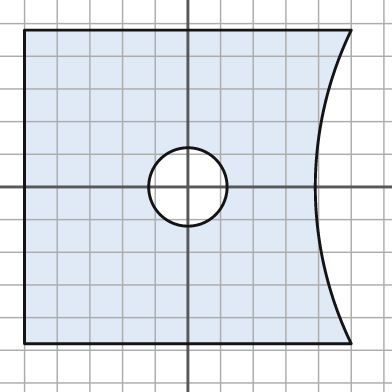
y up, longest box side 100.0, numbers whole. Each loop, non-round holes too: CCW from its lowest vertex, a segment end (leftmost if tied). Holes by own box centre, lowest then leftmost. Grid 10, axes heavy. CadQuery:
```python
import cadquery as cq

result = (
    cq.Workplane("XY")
    .moveTo(-50.0, -48.0)
    .lineTo(50.0, -48.0)
    .threePointArc((39.0, 0.0), (50.0, 48.0))
    .lineTo(-50.0, 48.0)
    .close()
    .moveTo(0.0, 0.0)
    .circle(12.0)
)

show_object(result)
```